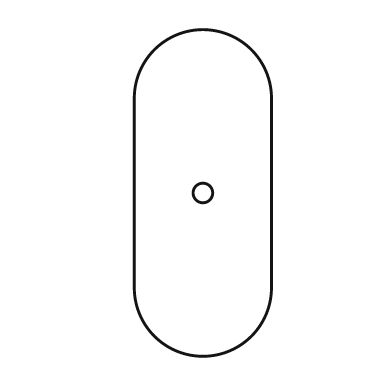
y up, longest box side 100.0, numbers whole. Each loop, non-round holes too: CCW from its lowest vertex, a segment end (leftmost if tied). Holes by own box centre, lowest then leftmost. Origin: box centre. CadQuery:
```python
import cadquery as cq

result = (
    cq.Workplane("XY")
    .moveTo(-21.0, -29.0)
    .threePointArc((0.0, -50.0), (21.0, -29.0))
    .lineTo(21.0, 29.0)
    .threePointArc((0.0, 50.0), (-21.0, 29.0))
    .close()
    .moveTo(0.0, 0.0)
    .circle(3.0)
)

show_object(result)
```